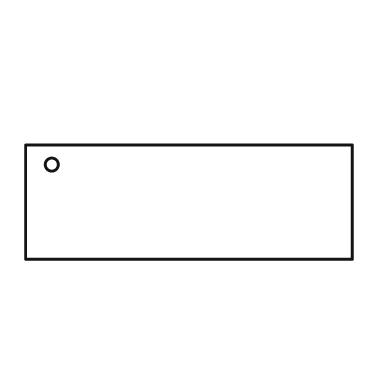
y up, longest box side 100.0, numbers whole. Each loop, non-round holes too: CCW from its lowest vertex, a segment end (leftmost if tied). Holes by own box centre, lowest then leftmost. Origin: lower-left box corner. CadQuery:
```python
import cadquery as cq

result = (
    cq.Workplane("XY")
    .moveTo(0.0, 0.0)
    .lineTo(100.0, 0.0)
    .lineTo(100.0, 35.0)
    .lineTo(0.0, 35.0)
    .close()
    .moveTo(8.0, 29.0)
    .circle(2.0)
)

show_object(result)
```